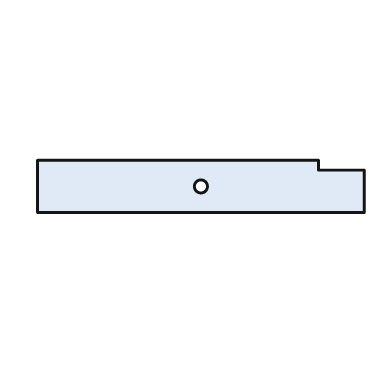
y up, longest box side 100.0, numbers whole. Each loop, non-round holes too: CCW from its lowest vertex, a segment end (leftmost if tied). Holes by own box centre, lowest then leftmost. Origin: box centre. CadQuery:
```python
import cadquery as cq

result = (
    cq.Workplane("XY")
    .moveTo(-50.0, -8.0)
    .lineTo(50.0, -8.0)
    .lineTo(50.0, 5.0)
    .lineTo(36.0, 5.0)
    .lineTo(36.0, 8.0)
    .lineTo(-50.0, 8.0)
    .close()
    .moveTo(0.0, 0.0)
    .circle(2.0)
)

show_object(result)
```